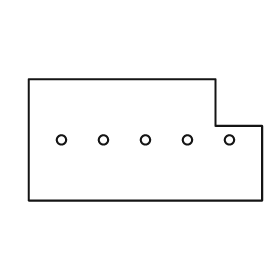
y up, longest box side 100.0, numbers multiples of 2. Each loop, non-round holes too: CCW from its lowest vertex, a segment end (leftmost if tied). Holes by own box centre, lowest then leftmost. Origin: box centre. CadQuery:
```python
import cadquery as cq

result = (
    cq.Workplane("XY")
    .moveTo(-50.0, -26.0)
    .lineTo(50.0, -26.0)
    .lineTo(50.0, 6.0)
    .lineTo(30.0, 6.0)
    .lineTo(30.0, 26.0)
    .lineTo(-50.0, 26.0)
    .close()
    .moveTo(-36.0, 0.0)
    .circle(2.0)
    .moveTo(-18.0, 0.0)
    .circle(2.0)
    .moveTo(0.0, 0.0)
    .circle(2.0)
    .moveTo(18.0, 0.0)
    .circle(2.0)
    .moveTo(36.0, 0.0)
    .circle(2.0)
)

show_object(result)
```